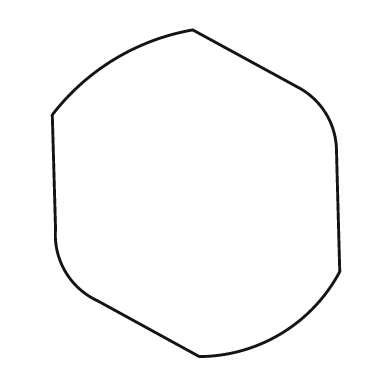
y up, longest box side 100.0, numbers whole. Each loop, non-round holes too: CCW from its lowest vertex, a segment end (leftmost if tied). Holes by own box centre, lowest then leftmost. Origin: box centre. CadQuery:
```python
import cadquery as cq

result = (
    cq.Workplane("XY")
    .moveTo(1.0, -50.0)
    .threePointArc((26.0, -43.0), (44.0, -24.0))
    .lineTo(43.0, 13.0)
    .threePointArc((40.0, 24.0), (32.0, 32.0))
    .lineTo(-1.0, 50.0)
    .threePointArc((-25.0, 41.0), (-44.0, 24.0))
    .lineTo(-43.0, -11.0)
    .threePointArc((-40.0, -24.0), (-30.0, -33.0))
    .close()
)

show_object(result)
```